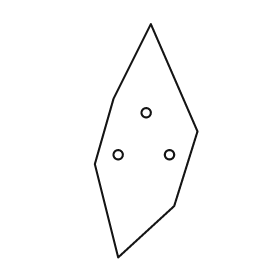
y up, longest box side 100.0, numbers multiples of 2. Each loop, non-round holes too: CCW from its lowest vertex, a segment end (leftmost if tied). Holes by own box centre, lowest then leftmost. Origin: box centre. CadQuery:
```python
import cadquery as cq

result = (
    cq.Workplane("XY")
    .moveTo(-12.0, -50.0)
    .lineTo(12.0, -28.0)
    .lineTo(22.0, 4.0)
    .lineTo(2.0, 50.0)
    .lineTo(-14.0, 18.0)
    .lineTo(-22.0, -10.0)
    .close()
    .moveTo(-12.0, -6.0)
    .circle(2.0)
    .moveTo(10.0, -6.0)
    .circle(2.0)
    .moveTo(0.0, 12.0)
    .circle(2.0)
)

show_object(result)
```